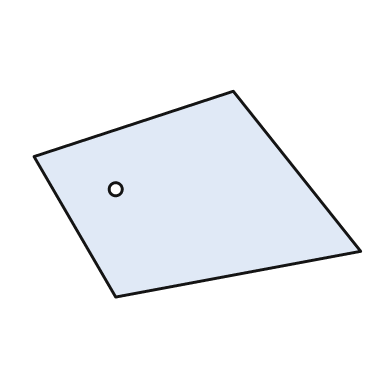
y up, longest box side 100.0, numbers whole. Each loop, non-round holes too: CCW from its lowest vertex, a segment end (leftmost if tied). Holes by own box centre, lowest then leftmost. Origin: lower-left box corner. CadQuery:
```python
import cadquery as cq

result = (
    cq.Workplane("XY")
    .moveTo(25.0, 0.0)
    .lineTo(100.0, 14.0)
    .lineTo(61.0, 63.0)
    .lineTo(0.0, 43.0)
    .close()
    .moveTo(25.0, 33.0)
    .circle(2.0)
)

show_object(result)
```